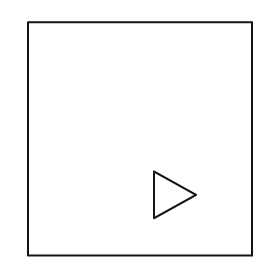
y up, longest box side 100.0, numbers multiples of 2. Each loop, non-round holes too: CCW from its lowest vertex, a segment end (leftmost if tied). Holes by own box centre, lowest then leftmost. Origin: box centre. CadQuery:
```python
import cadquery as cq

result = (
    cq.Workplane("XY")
    .moveTo(-48.0, -50.0)
    .lineTo(48.0, -50.0)
    .lineTo(48.0, 50.0)
    .lineTo(-48.0, 50.0)
    .close()
    .moveTo(6.0, -34.0)
    .lineTo(24.0, -24.0)
    .lineTo(6.0, -14.0)
    .close()
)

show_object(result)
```